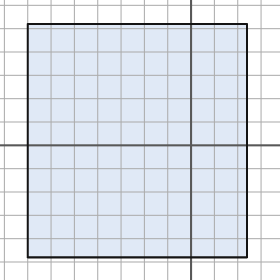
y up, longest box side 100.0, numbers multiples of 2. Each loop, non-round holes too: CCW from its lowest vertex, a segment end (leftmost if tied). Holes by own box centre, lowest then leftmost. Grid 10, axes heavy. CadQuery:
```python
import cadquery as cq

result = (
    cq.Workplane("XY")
    .moveTo(-70.0, -48.0)
    .lineTo(24.0, -48.0)
    .lineTo(24.0, 52.0)
    .lineTo(-70.0, 52.0)
    .close()
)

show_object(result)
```